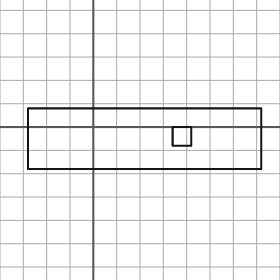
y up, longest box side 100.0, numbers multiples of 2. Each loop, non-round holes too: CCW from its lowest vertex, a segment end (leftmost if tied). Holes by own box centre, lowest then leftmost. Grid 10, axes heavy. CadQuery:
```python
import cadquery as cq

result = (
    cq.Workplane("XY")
    .moveTo(-28.0, -18.0)
    .lineTo(72.0, -18.0)
    .lineTo(72.0, 8.0)
    .lineTo(-28.0, 8.0)
    .close()
    .moveTo(34.0, -8.0)
    .lineTo(42.0, -8.0)
    .lineTo(42.0, 0.0)
    .lineTo(34.0, 0.0)
    .close()
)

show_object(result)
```